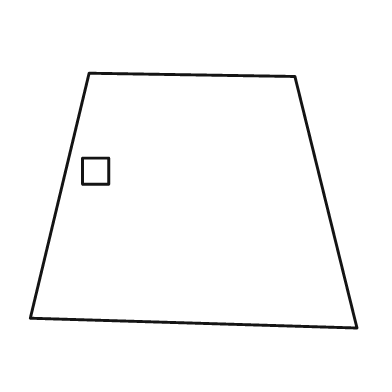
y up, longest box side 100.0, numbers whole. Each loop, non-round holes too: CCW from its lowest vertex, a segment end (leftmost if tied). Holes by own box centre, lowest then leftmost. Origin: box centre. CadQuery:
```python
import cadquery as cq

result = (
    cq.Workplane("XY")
    .moveTo(50.0, -39.0)
    .lineTo(31.0, 38.0)
    .lineTo(-32.0, 39.0)
    .lineTo(-50.0, -36.0)
    .close()
    .moveTo(-34.0, 5.0)
    .lineTo(-26.0, 5.0)
    .lineTo(-26.0, 13.0)
    .lineTo(-34.0, 13.0)
    .close()
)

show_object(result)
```